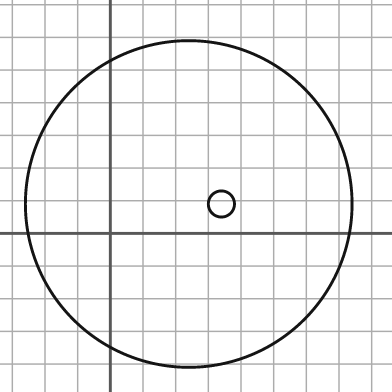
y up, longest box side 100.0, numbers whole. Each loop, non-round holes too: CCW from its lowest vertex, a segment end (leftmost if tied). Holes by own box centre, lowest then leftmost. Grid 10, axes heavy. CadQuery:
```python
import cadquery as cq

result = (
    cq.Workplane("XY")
    .moveTo(24.0, 9.0)
    .circle(50.0)
    .moveTo(34.0, 9.0)
    .circle(4.0)
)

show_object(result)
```